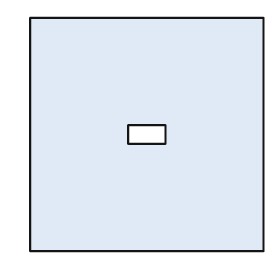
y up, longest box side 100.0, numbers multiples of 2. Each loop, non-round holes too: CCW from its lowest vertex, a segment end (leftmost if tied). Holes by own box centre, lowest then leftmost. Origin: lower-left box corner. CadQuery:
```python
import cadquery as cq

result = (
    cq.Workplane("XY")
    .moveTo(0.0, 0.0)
    .lineTo(100.0, 0.0)
    .lineTo(100.0, 100.0)
    .lineTo(0.0, 100.0)
    .close()
    .moveTo(42.0, 46.0)
    .lineTo(58.0, 46.0)
    .lineTo(58.0, 54.0)
    .lineTo(42.0, 54.0)
    .close()
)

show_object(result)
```